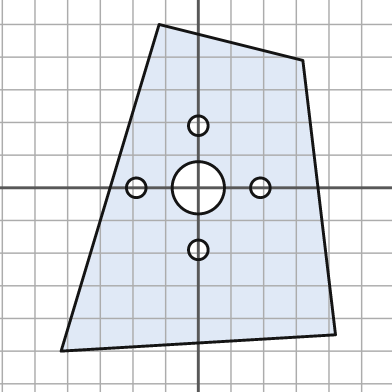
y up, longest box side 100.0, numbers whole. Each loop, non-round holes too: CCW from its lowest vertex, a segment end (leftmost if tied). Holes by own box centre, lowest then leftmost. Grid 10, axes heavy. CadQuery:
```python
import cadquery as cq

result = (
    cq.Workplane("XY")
    .moveTo(-42.0, -50.0)
    .lineTo(42.0, -45.0)
    .lineTo(32.0, 39.0)
    .lineTo(-12.0, 50.0)
    .close()
    .moveTo(0.0, -19.0)
    .circle(3.0)
    .moveTo(-19.0, 0.0)
    .circle(3.0)
    .moveTo(0.0, 0.0)
    .circle(8.0)
    .moveTo(19.0, 0.0)
    .circle(3.0)
    .moveTo(0.0, 19.0)
    .circle(3.0)
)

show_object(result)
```